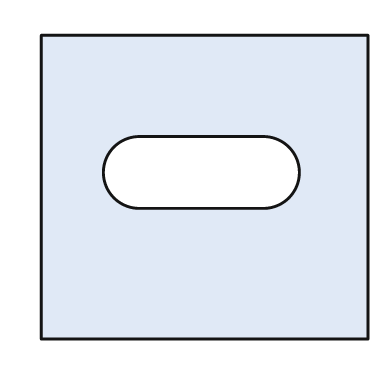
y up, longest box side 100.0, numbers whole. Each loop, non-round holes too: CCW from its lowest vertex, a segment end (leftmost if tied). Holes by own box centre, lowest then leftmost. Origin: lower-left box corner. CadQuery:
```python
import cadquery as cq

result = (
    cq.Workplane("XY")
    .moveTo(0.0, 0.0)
    .lineTo(100.0, 0.0)
    .lineTo(100.0, 93.0)
    .lineTo(0.0, 93.0)
    .close()
    .moveTo(30.0, 40.0)
    .lineTo(68.0, 40.0)
    .threePointArc((79.0, 51.0), (68.0, 62.0))
    .lineTo(30.0, 62.0)
    .threePointArc((19.0, 51.0), (30.0, 40.0))
    .close()
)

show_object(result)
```